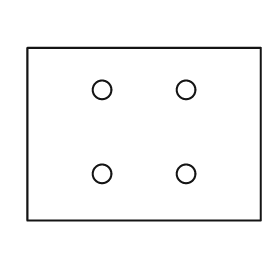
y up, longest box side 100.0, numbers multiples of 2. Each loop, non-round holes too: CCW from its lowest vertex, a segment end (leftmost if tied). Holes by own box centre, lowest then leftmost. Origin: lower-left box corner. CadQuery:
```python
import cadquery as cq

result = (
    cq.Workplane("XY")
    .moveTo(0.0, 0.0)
    .lineTo(100.0, 0.0)
    .lineTo(100.0, 74.0)
    .lineTo(0.0, 74.0)
    .close()
    .moveTo(32.0, 20.0)
    .circle(4.0)
    .moveTo(68.0, 20.0)
    .circle(4.0)
    .moveTo(32.0, 56.0)
    .circle(4.0)
    .moveTo(68.0, 56.0)
    .circle(4.0)
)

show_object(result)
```